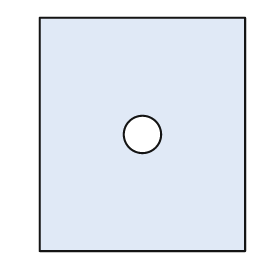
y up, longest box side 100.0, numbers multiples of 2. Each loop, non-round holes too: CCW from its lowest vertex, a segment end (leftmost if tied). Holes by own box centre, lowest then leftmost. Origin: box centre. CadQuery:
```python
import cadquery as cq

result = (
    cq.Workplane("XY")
    .moveTo(-44.0, -50.0)
    .lineTo(44.0, -50.0)
    .lineTo(44.0, 50.0)
    .lineTo(-44.0, 50.0)
    .close()
    .moveTo(0.0, 0.0)
    .circle(8.0)
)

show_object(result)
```